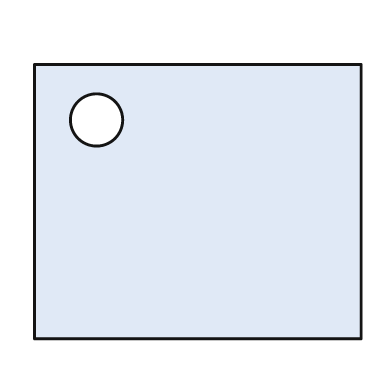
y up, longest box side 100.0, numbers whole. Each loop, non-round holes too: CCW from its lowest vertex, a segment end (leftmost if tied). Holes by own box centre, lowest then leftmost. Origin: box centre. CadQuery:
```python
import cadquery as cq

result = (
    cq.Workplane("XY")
    .moveTo(-50.0, -42.0)
    .lineTo(50.0, -42.0)
    .lineTo(50.0, 42.0)
    .lineTo(-50.0, 42.0)
    .close()
    .moveTo(-31.0, 25.0)
    .circle(8.0)
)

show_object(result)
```